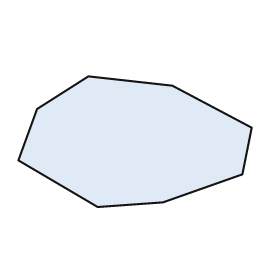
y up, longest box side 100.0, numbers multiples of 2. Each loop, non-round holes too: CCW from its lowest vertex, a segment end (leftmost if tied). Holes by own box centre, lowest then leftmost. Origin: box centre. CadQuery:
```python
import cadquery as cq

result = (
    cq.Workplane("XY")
    .moveTo(-16.0, -28.0)
    .lineTo(12.0, -26.0)
    .lineTo(46.0, -14.0)
    .lineTo(50.0, 6.0)
    .lineTo(16.0, 24.0)
    .lineTo(-20.0, 28.0)
    .lineTo(-42.0, 14.0)
    .lineTo(-50.0, -8.0)
    .close()
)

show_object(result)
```